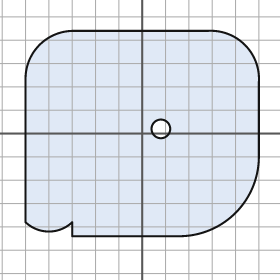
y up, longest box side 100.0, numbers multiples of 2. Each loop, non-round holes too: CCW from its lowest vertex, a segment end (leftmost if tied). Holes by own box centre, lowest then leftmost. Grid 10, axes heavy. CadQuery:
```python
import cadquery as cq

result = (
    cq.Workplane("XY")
    .moveTo(-30.0, -44.0)
    .lineTo(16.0, -44.0)
    .threePointArc((40.0, -34.0), (50.0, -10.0))
    .lineTo(50.0, 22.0)
    .threePointArc((44.0, 38.0), (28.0, 44.0))
    .lineTo(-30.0, 44.0)
    .threePointArc((-44.0, 38.0), (-50.0, 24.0))
    .lineTo(-50.0, -38.0)
    .threePointArc((-40.0, -42.0), (-30.0, -38.0))
    .close()
    .moveTo(8.0, 2.0)
    .circle(4.0)
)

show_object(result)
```